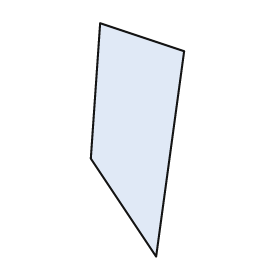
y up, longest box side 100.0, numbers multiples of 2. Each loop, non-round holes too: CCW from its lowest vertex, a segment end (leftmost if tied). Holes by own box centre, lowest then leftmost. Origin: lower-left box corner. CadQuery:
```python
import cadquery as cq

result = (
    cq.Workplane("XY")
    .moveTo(28.0, 0.0)
    .lineTo(40.0, 88.0)
    .lineTo(4.0, 100.0)
    .lineTo(0.0, 42.0)
    .close()
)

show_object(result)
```